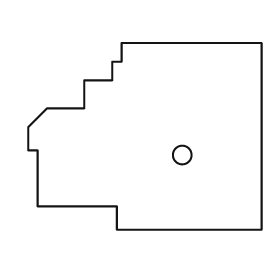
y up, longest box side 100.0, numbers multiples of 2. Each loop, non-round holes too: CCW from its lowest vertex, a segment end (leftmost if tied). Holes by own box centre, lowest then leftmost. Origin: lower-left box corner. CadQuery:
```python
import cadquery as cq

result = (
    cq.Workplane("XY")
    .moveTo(38.0, 0.0)
    .lineTo(100.0, 0.0)
    .lineTo(100.0, 80.0)
    .lineTo(40.0, 80.0)
    .lineTo(40.0, 72.0)
    .lineTo(36.0, 72.0)
    .lineTo(36.0, 64.0)
    .lineTo(24.0, 64.0)
    .lineTo(24.0, 52.0)
    .lineTo(8.0, 52.0)
    .lineTo(0.0, 44.0)
    .lineTo(0.0, 34.0)
    .lineTo(4.0, 34.0)
    .lineTo(4.0, 10.0)
    .lineTo(38.0, 10.0)
    .close()
    .moveTo(66.0, 32.0)
    .circle(4.0)
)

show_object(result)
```